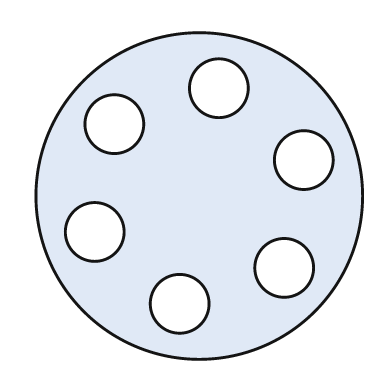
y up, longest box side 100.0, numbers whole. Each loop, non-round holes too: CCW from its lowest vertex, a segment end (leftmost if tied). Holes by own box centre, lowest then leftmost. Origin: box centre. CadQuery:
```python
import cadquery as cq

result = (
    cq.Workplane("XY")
    .moveTo(0.0, 0.0)
    .circle(50.0)
    .moveTo(-6.0, -33.0)
    .circle(9.0)
    .moveTo(26.0, -22.0)
    .circle(9.0)
    .moveTo(-32.0, -11.0)
    .circle(9.0)
    .moveTo(32.0, 11.0)
    .circle(9.0)
    .moveTo(-26.0, 22.0)
    .circle(9.0)
    .moveTo(6.0, 33.0)
    .circle(9.0)
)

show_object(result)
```